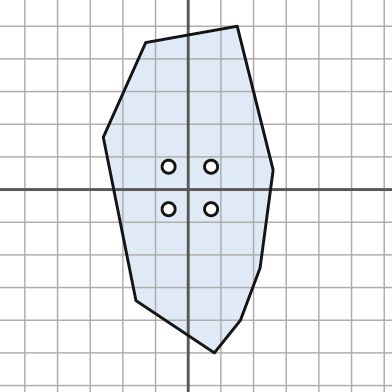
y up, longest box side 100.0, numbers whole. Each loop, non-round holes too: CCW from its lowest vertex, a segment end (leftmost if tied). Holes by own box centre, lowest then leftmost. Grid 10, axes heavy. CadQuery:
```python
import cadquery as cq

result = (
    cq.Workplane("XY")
    .moveTo(8.0, -50.0)
    .lineTo(16.0, -40.0)
    .lineTo(22.0, -24.0)
    .lineTo(26.0, 6.0)
    .lineTo(15.0, 50.0)
    .lineTo(-13.0, 45.0)
    .lineTo(-26.0, 16.0)
    .lineTo(-16.0, -34.0)
    .close()
    .moveTo(-6.0, -6.0)
    .circle(2.0)
    .moveTo(7.0, -6.0)
    .circle(2.0)
    .moveTo(-6.0, 7.0)
    .circle(2.0)
    .moveTo(7.0, 7.0)
    .circle(2.0)
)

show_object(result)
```